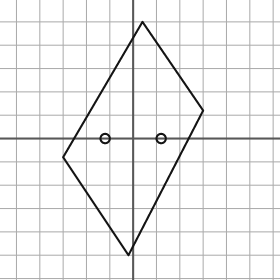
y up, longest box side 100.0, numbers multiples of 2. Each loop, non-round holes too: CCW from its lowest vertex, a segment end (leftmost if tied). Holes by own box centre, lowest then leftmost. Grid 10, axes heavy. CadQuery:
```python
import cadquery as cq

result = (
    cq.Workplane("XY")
    .moveTo(-2.0, -50.0)
    .lineTo(30.0, 12.0)
    .lineTo(4.0, 50.0)
    .lineTo(-30.0, -8.0)
    .close()
    .moveTo(-12.0, 0.0)
    .circle(2.0)
    .moveTo(12.0, 0.0)
    .circle(2.0)
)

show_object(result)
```